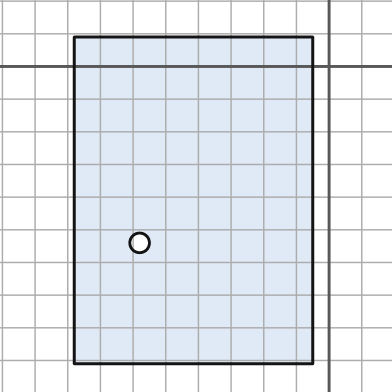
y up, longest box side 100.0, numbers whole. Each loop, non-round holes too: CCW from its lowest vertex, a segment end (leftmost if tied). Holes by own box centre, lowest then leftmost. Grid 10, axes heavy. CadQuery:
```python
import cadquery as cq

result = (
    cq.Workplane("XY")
    .moveTo(-78.0, -91.0)
    .lineTo(-5.0, -91.0)
    .lineTo(-5.0, 9.0)
    .lineTo(-78.0, 9.0)
    .close()
    .moveTo(-58.0, -54.0)
    .circle(3.0)
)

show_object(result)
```